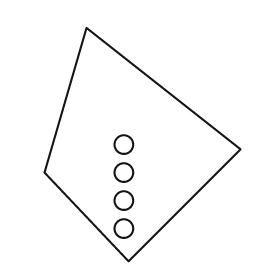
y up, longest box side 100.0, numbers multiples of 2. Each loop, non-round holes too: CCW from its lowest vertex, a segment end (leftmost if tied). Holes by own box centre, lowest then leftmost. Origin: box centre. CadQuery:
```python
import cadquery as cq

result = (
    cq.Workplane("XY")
    .moveTo(-6.0, -50.0)
    .lineTo(42.0, -2.0)
    .lineTo(-24.0, 50.0)
    .lineTo(-42.0, -12.0)
    .close()
    .moveTo(-8.0, -36.0)
    .circle(4.0)
    .moveTo(-8.0, -24.0)
    .circle(4.0)
    .moveTo(-8.0, -12.0)
    .circle(4.0)
    .moveTo(-8.0, 0.0)
    .circle(4.0)
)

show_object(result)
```